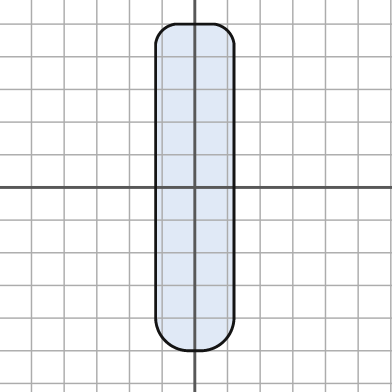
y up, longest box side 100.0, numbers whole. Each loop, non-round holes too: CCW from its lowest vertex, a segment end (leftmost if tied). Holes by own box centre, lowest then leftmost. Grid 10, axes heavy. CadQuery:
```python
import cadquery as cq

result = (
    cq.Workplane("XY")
    .moveTo(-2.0, -50.0)
    .lineTo(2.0, -50.0)
    .threePointArc((9.0, -47.0), (12.0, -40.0))
    .lineTo(12.0, 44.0)
    .threePointArc((10.0, 48.0), (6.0, 50.0))
    .lineTo(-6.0, 50.0)
    .threePointArc((-10.0, 48.0), (-12.0, 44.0))
    .lineTo(-12.0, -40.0)
    .threePointArc((-9.0, -47.0), (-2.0, -50.0))
    .close()
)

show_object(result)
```